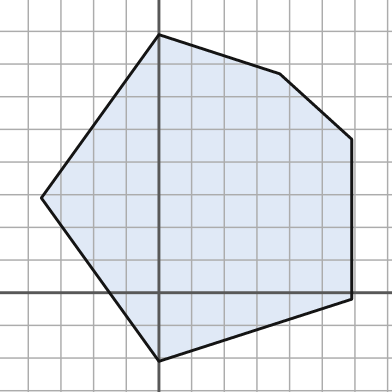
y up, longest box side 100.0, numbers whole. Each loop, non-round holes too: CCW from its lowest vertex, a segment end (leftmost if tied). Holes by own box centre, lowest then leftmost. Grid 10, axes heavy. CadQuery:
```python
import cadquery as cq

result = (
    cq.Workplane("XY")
    .moveTo(0.0, -21.0)
    .lineTo(59.0, -2.0)
    .lineTo(59.0, 47.0)
    .lineTo(37.0, 67.0)
    .lineTo(0.0, 79.0)
    .lineTo(-36.0, 29.0)
    .close()
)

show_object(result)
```